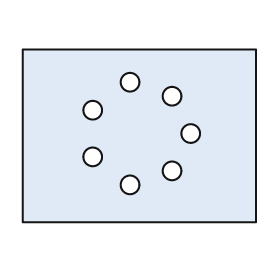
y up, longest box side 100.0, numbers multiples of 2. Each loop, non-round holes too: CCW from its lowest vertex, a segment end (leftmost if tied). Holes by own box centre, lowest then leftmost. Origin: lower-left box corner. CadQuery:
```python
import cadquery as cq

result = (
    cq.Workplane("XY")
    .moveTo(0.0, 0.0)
    .lineTo(100.0, 0.0)
    .lineTo(100.0, 74.0)
    .lineTo(0.0, 74.0)
    .close()
    .moveTo(46.0, 16.0)
    .circle(4.0)
    .moveTo(64.0, 22.0)
    .circle(4.0)
    .moveTo(30.0, 28.0)
    .circle(4.0)
    .moveTo(72.0, 38.0)
    .circle(4.0)
    .moveTo(30.0, 48.0)
    .circle(4.0)
    .moveTo(64.0, 54.0)
    .circle(4.0)
    .moveTo(46.0, 60.0)
    .circle(4.0)
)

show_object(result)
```